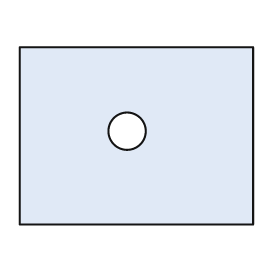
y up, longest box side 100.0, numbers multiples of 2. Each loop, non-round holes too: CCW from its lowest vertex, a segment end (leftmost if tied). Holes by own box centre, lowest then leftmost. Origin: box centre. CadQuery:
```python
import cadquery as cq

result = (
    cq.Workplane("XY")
    .moveTo(-50.0, -38.0)
    .lineTo(50.0, -38.0)
    .lineTo(50.0, 38.0)
    .lineTo(-50.0, 38.0)
    .close()
    .moveTo(-4.0, 2.0)
    .circle(8.0)
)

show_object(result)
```